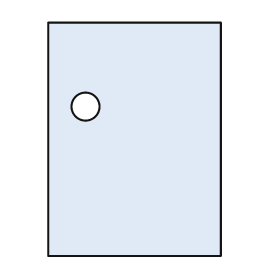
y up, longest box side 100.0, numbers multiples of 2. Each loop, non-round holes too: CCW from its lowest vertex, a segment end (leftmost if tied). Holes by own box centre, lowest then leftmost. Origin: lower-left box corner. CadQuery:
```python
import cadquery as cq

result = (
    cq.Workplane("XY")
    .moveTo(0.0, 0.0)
    .lineTo(74.0, 0.0)
    .lineTo(74.0, 100.0)
    .lineTo(0.0, 100.0)
    .close()
    .moveTo(16.0, 64.0)
    .circle(6.0)
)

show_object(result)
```